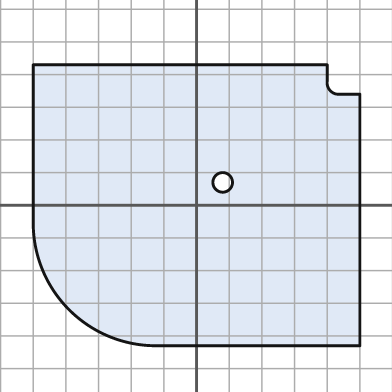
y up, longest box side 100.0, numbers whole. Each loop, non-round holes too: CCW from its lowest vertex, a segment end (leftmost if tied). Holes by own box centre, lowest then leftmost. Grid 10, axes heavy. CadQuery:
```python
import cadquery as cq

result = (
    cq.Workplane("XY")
    .moveTo(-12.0, -43.0)
    .lineTo(50.0, -43.0)
    .lineTo(50.0, 34.0)
    .lineTo(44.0, 34.0)
    .threePointArc((41.0, 35.0), (40.0, 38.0))
    .lineTo(40.0, 43.0)
    .lineTo(-50.0, 43.0)
    .lineTo(-50.0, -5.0)
    .threePointArc((-39.0, -32.0), (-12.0, -43.0))
    .close()
    .moveTo(8.0, 7.0)
    .circle(3.0)
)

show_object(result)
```